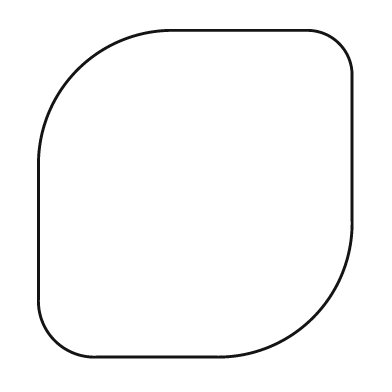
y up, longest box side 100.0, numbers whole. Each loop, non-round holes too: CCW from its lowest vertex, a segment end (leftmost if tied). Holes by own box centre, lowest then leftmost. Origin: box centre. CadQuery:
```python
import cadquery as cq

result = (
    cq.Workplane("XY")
    .moveTo(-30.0, -50.0)
    .lineTo(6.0, -50.0)
    .threePointArc((36.0, -38.0), (48.0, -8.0))
    .lineTo(48.0, 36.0)
    .threePointArc((44.0, 46.0), (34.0, 50.0))
    .lineTo(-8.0, 50.0)
    .threePointArc((-36.0, 38.0), (-48.0, 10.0))
    .lineTo(-48.0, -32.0)
    .threePointArc((-43.0, -45.0), (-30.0, -50.0))
    .close()
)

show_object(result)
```